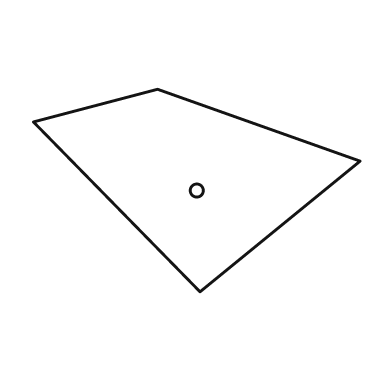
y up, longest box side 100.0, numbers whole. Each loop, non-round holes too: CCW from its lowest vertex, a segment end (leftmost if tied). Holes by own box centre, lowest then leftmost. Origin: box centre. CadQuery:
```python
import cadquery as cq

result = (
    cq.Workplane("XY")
    .moveTo(1.0, -31.0)
    .lineTo(50.0, 9.0)
    .lineTo(-12.0, 31.0)
    .lineTo(-50.0, 21.0)
    .close()
    .moveTo(0.0, 0.0)
    .circle(2.0)
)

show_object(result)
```